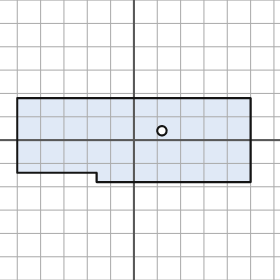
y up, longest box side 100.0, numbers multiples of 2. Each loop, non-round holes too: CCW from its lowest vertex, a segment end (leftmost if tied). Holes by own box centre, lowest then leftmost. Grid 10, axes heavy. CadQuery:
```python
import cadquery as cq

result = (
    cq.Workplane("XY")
    .moveTo(-16.0, -18.0)
    .lineTo(50.0, -18.0)
    .lineTo(50.0, 18.0)
    .lineTo(-50.0, 18.0)
    .lineTo(-50.0, -14.0)
    .lineTo(-16.0, -14.0)
    .close()
    .moveTo(12.0, 4.0)
    .circle(2.0)
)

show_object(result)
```